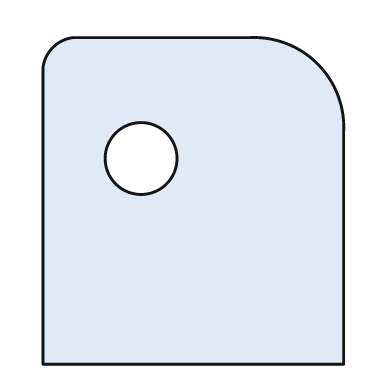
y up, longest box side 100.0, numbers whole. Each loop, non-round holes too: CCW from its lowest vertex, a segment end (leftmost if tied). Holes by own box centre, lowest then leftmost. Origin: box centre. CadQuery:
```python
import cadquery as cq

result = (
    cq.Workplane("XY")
    .moveTo(-46.0, -50.0)
    .lineTo(46.0, -50.0)
    .lineTo(46.0, 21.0)
    .threePointArc((38.0, 42.0), (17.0, 50.0))
    .lineTo(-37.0, 50.0)
    .threePointArc((-43.0, 47.0), (-46.0, 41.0))
    .close()
    .moveTo(-16.0, 13.0)
    .circle(11.0)
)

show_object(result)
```